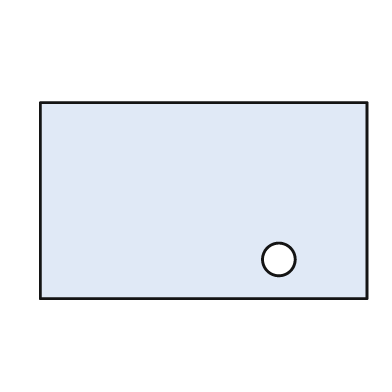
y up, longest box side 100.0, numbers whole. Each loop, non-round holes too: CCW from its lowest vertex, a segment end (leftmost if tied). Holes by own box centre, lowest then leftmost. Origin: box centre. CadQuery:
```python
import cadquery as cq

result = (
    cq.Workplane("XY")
    .moveTo(-50.0, -30.0)
    .lineTo(50.0, -30.0)
    .lineTo(50.0, 30.0)
    .lineTo(-50.0, 30.0)
    .close()
    .moveTo(23.0, -18.0)
    .circle(5.0)
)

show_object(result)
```